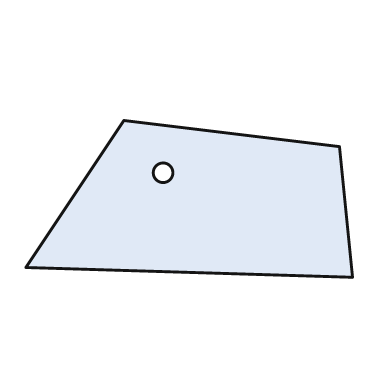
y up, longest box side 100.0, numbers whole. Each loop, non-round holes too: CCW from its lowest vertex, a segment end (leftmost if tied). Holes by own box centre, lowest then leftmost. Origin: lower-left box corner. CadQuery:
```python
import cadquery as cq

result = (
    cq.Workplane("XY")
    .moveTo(100.0, 0.0)
    .lineTo(96.0, 40.0)
    .lineTo(30.0, 48.0)
    .lineTo(0.0, 3.0)
    .close()
    .moveTo(42.0, 32.0)
    .circle(3.0)
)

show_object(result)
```